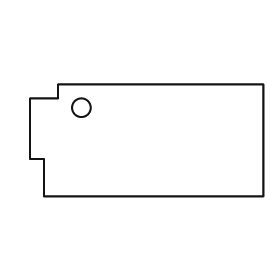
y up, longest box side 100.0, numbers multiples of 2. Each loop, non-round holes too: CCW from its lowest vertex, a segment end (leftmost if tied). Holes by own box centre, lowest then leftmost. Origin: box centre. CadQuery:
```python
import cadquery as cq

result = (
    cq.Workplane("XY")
    .moveTo(-44.0, -24.0)
    .lineTo(50.0, -24.0)
    .lineTo(50.0, 24.0)
    .lineTo(-38.0, 24.0)
    .lineTo(-38.0, 18.0)
    .lineTo(-50.0, 18.0)
    .lineTo(-50.0, -8.0)
    .lineTo(-44.0, -8.0)
    .close()
    .moveTo(-28.0, 14.0)
    .circle(4.0)
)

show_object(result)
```